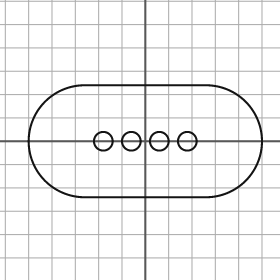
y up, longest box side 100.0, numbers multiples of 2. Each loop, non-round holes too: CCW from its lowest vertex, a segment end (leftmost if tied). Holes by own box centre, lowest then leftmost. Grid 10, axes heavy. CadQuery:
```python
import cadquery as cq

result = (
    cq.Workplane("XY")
    .moveTo(-26.0, -24.0)
    .lineTo(26.0, -24.0)
    .threePointArc((50.0, 0.0), (26.0, 24.0))
    .lineTo(-26.0, 24.0)
    .threePointArc((-50.0, 0.0), (-26.0, -24.0))
    .close()
    .moveTo(-18.0, 0.0)
    .circle(4.0)
    .moveTo(-6.0, 0.0)
    .circle(4.0)
    .moveTo(6.0, 0.0)
    .circle(4.0)
    .moveTo(18.0, 0.0)
    .circle(4.0)
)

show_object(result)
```